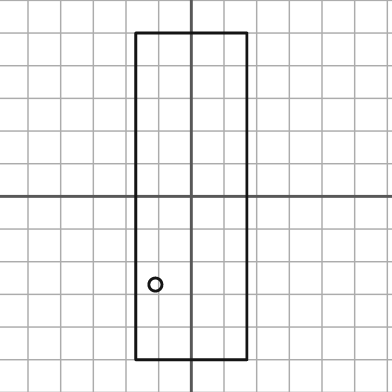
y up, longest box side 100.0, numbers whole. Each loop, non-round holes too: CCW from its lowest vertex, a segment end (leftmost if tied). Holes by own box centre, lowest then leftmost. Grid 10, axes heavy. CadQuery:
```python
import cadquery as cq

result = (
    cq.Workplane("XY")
    .moveTo(-17.0, -50.0)
    .lineTo(17.0, -50.0)
    .lineTo(17.0, 50.0)
    .lineTo(-17.0, 50.0)
    .close()
    .moveTo(-11.0, -27.0)
    .circle(2.0)
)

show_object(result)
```